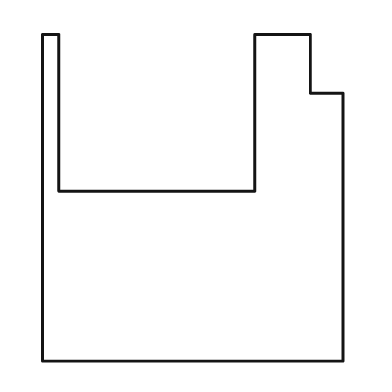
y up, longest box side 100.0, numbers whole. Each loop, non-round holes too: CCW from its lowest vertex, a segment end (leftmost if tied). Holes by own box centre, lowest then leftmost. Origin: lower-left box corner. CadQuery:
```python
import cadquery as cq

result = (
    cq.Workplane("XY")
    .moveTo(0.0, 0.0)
    .lineTo(92.0, 0.0)
    .lineTo(92.0, 82.0)
    .lineTo(82.0, 82.0)
    .lineTo(82.0, 100.0)
    .lineTo(65.0, 100.0)
    .lineTo(65.0, 52.0)
    .lineTo(5.0, 52.0)
    .lineTo(5.0, 100.0)
    .lineTo(0.0, 100.0)
    .close()
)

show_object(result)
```